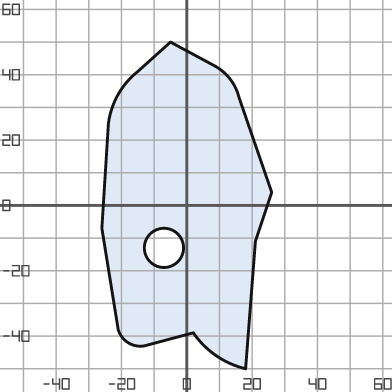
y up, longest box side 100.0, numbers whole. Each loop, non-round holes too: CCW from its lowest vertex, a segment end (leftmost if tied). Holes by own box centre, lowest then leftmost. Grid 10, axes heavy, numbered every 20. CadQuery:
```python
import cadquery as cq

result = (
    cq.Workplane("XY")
    .moveTo(18.0, -50.0)
    .lineTo(21.0, -11.0)
    .lineTo(26.0, 4.0)
    .lineTo(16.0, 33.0)
    .threePointArc((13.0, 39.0), (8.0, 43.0))
    .lineTo(-5.0, 50.0)
    .lineTo(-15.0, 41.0)
    .threePointArc((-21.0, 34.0), (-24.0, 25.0))
    .lineTo(-26.0, -7.0)
    .lineTo(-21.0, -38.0)
    .threePointArc((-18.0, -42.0), (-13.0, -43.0))
    .lineTo(2.0, -39.0)
    .threePointArc((9.0, -46.0), (18.0, -50.0))
    .close()
    .moveTo(-7.0, -13.0)
    .circle(6.0)
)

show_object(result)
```